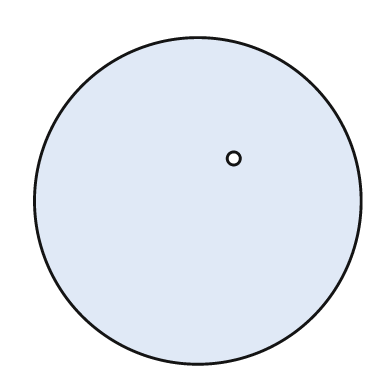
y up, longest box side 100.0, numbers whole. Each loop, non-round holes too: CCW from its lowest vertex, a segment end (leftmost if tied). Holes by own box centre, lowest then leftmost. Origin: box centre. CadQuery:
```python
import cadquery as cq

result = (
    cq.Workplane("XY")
    .moveTo(0.0, 0.0)
    .circle(50.0)
    .moveTo(11.0, 13.0)
    .circle(2.0)
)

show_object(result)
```